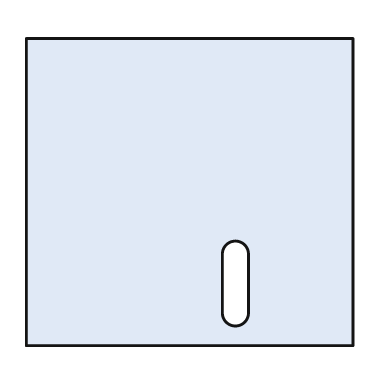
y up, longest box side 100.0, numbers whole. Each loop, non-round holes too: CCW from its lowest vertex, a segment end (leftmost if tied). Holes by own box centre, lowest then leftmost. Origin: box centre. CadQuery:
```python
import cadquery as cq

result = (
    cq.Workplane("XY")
    .moveTo(-50.0, -47.0)
    .lineTo(50.0, -47.0)
    .lineTo(50.0, 47.0)
    .lineTo(-50.0, 47.0)
    .close()
    .moveTo(10.0, -37.0)
    .threePointArc((14.0, -41.0), (18.0, -37.0))
    .lineTo(18.0, -19.0)
    .threePointArc((14.0, -15.0), (10.0, -19.0))
    .close()
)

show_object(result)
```